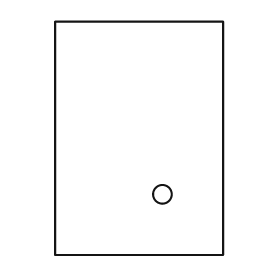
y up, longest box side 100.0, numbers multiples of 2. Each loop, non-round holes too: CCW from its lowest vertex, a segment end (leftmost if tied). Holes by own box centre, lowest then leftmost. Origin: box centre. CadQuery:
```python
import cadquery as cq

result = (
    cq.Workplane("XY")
    .moveTo(-36.0, -50.0)
    .lineTo(36.0, -50.0)
    .lineTo(36.0, 50.0)
    .lineTo(-36.0, 50.0)
    .close()
    .moveTo(10.0, -24.0)
    .circle(4.0)
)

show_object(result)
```